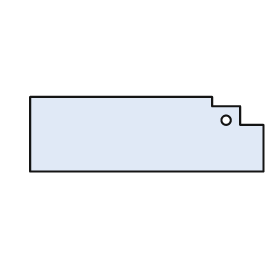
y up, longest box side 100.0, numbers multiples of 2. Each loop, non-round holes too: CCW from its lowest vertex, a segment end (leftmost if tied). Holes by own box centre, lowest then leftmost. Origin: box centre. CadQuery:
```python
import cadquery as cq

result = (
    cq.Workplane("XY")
    .moveTo(-50.0, -16.0)
    .lineTo(50.0, -16.0)
    .lineTo(50.0, 4.0)
    .lineTo(40.0, 4.0)
    .lineTo(40.0, 12.0)
    .lineTo(28.0, 12.0)
    .lineTo(28.0, 16.0)
    .lineTo(-50.0, 16.0)
    .close()
    .moveTo(34.0, 6.0)
    .circle(2.0)
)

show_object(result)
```